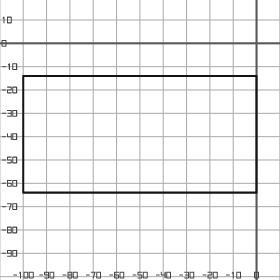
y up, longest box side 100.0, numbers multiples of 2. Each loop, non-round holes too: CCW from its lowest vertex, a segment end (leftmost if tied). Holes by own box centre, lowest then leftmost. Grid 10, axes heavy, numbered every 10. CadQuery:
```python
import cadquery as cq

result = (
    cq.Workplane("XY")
    .moveTo(-100.0, -64.0)
    .lineTo(0.0, -64.0)
    .lineTo(0.0, -14.0)
    .lineTo(-100.0, -14.0)
    .close()
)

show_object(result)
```